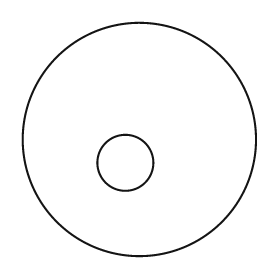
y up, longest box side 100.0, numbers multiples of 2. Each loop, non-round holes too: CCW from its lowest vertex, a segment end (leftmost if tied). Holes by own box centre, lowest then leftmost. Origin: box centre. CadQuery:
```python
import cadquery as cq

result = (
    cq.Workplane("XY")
    .moveTo(0.0, 0.0)
    .circle(50.0)
    .moveTo(-6.0, -10.0)
    .circle(12.0)
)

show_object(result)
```